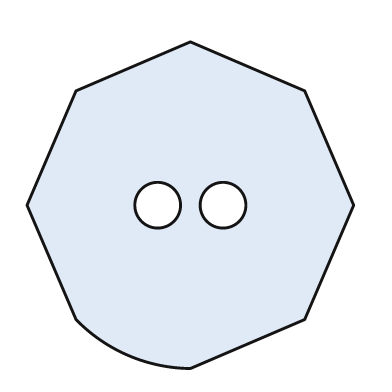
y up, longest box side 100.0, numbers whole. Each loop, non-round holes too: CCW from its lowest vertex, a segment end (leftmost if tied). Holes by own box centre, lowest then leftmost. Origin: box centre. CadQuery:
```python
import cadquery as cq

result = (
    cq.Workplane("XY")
    .moveTo(0.0, -50.0)
    .lineTo(35.0, -35.0)
    .lineTo(50.0, 0.0)
    .lineTo(35.0, 35.0)
    .lineTo(0.0, 50.0)
    .lineTo(-35.0, 35.0)
    .lineTo(-50.0, 0.0)
    .lineTo(-35.0, -35.0)
    .threePointArc((-19.0, -46.0), (0.0, -50.0))
    .close()
    .moveTo(-10.0, 0.0)
    .circle(7.0)
    .moveTo(10.0, 0.0)
    .circle(7.0)
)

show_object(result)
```